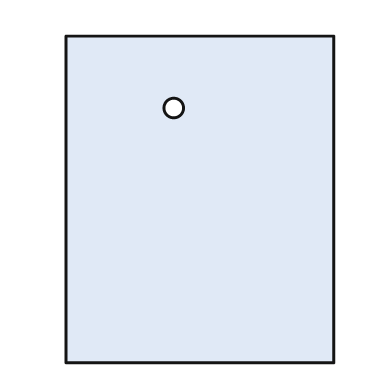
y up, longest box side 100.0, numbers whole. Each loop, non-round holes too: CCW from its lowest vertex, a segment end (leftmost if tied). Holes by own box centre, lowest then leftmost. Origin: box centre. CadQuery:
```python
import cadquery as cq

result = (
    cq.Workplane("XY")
    .moveTo(-41.0, -50.0)
    .lineTo(41.0, -50.0)
    .lineTo(41.0, 50.0)
    .lineTo(-41.0, 50.0)
    .close()
    .moveTo(-8.0, 28.0)
    .circle(3.0)
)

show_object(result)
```